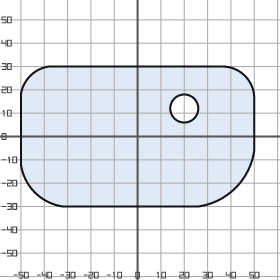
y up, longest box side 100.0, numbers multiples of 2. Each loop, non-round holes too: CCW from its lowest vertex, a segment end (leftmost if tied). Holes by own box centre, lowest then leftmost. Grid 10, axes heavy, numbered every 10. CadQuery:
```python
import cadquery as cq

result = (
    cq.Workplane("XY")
    .moveTo(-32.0, -30.0)
    .lineTo(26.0, -30.0)
    .threePointArc((42.0, -22.0), (50.0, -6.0))
    .lineTo(50.0, 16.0)
    .threePointArc((46.0, 26.0), (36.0, 30.0))
    .lineTo(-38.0, 30.0)
    .threePointArc((-46.0, 26.0), (-50.0, 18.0))
    .lineTo(-50.0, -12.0)
    .threePointArc((-44.0, -24.0), (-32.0, -30.0))
    .close()
    .moveTo(20.0, 12.0)
    .circle(6.0)
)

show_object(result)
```